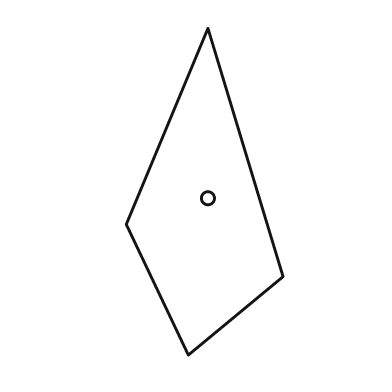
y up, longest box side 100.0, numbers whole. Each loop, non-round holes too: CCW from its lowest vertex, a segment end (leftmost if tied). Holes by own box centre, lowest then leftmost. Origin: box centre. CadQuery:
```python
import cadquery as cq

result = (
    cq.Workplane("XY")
    .moveTo(-5.0, -50.0)
    .lineTo(24.0, -26.0)
    .lineTo(1.0, 50.0)
    .lineTo(-24.0, -10.0)
    .close()
    .moveTo(1.0, -2.0)
    .circle(2.0)
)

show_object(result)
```